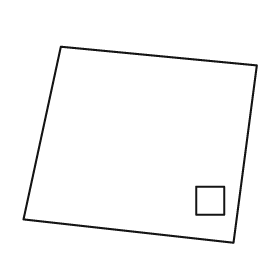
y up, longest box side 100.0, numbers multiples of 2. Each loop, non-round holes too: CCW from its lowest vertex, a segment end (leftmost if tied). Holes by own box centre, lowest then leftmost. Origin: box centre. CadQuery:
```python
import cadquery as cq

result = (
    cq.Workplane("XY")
    .moveTo(40.0, -42.0)
    .lineTo(50.0, 34.0)
    .lineTo(-34.0, 42.0)
    .lineTo(-50.0, -32.0)
    .close()
    .moveTo(24.0, -30.0)
    .lineTo(36.0, -30.0)
    .lineTo(36.0, -18.0)
    .lineTo(24.0, -18.0)
    .close()
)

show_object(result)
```